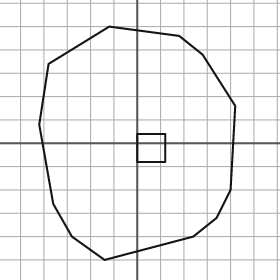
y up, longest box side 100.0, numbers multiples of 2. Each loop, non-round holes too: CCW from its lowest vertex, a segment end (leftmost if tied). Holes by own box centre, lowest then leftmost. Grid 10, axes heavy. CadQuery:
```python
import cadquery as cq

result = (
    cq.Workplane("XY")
    .moveTo(-14.0, -50.0)
    .lineTo(24.0, -40.0)
    .lineTo(34.0, -32.0)
    .lineTo(40.0, -20.0)
    .lineTo(42.0, 16.0)
    .lineTo(28.0, 38.0)
    .lineTo(18.0, 46.0)
    .lineTo(-12.0, 50.0)
    .lineTo(-38.0, 34.0)
    .lineTo(-42.0, 8.0)
    .lineTo(-36.0, -26.0)
    .lineTo(-28.0, -40.0)
    .close()
    .moveTo(0.0, -8.0)
    .lineTo(12.0, -8.0)
    .lineTo(12.0, 4.0)
    .lineTo(0.0, 4.0)
    .close()
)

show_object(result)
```